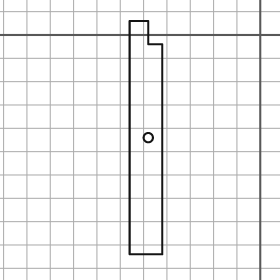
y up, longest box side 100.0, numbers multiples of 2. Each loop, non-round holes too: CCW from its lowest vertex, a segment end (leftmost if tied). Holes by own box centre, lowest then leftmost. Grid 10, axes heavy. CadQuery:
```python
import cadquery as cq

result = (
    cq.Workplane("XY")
    .moveTo(-56.0, -94.0)
    .lineTo(-42.0, -94.0)
    .lineTo(-42.0, -4.0)
    .lineTo(-48.0, -4.0)
    .lineTo(-48.0, 6.0)
    .lineTo(-56.0, 6.0)
    .close()
    .moveTo(-48.0, -44.0)
    .circle(2.0)
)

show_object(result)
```